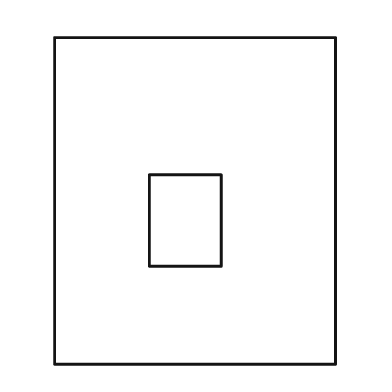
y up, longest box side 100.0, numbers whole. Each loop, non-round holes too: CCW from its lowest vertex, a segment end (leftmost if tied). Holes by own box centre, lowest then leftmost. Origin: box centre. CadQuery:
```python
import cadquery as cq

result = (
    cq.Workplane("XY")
    .moveTo(-43.0, -50.0)
    .lineTo(43.0, -50.0)
    .lineTo(43.0, 50.0)
    .lineTo(-43.0, 50.0)
    .close()
    .moveTo(-14.0, -20.0)
    .lineTo(8.0, -20.0)
    .lineTo(8.0, 8.0)
    .lineTo(-14.0, 8.0)
    .close()
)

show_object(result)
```